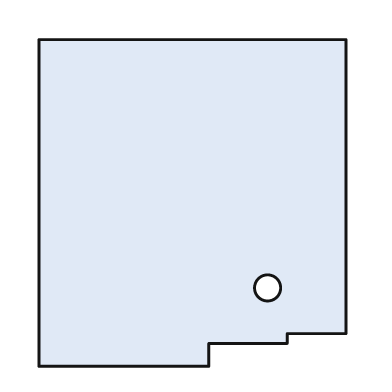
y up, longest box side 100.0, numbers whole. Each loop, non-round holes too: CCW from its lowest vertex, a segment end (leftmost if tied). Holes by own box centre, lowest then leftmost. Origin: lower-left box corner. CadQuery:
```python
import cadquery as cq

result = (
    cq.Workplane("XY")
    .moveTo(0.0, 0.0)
    .lineTo(52.0, 0.0)
    .lineTo(52.0, 7.0)
    .lineTo(76.0, 7.0)
    .lineTo(76.0, 10.0)
    .lineTo(94.0, 10.0)
    .lineTo(94.0, 100.0)
    .lineTo(0.0, 100.0)
    .close()
    .moveTo(70.0, 24.0)
    .circle(4.0)
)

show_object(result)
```